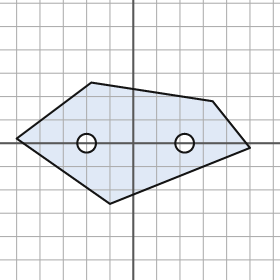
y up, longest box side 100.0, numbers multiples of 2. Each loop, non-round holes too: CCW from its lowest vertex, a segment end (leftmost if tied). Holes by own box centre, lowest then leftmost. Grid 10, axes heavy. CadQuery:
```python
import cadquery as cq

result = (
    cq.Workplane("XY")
    .moveTo(-10.0, -26.0)
    .lineTo(50.0, -2.0)
    .lineTo(34.0, 18.0)
    .lineTo(-18.0, 26.0)
    .lineTo(-50.0, 2.0)
    .close()
    .moveTo(-20.0, 0.0)
    .circle(4.0)
    .moveTo(22.0, 0.0)
    .circle(4.0)
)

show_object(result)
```